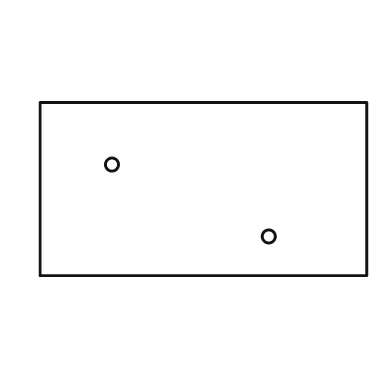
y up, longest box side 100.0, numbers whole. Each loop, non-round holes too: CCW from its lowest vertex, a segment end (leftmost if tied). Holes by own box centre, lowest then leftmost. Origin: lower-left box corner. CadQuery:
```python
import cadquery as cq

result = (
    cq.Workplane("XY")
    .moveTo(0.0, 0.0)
    .lineTo(100.0, 0.0)
    .lineTo(100.0, 53.0)
    .lineTo(0.0, 53.0)
    .close()
    .moveTo(70.0, 12.0)
    .circle(2.0)
    .moveTo(22.0, 34.0)
    .circle(2.0)
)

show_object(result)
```